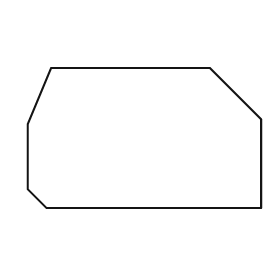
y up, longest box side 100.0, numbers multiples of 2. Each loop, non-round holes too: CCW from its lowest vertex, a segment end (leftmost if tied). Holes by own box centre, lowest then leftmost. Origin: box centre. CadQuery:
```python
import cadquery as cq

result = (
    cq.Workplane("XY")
    .moveTo(-42.0, -30.0)
    .lineTo(50.0, -30.0)
    .lineTo(50.0, 8.0)
    .lineTo(28.0, 30.0)
    .lineTo(-40.0, 30.0)
    .lineTo(-50.0, 6.0)
    .lineTo(-50.0, -22.0)
    .close()
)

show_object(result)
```